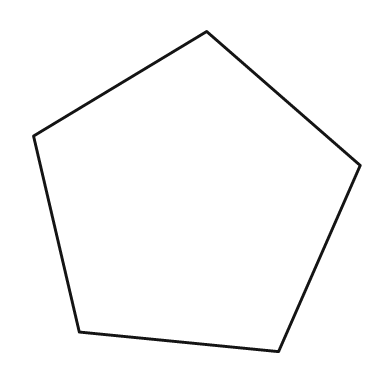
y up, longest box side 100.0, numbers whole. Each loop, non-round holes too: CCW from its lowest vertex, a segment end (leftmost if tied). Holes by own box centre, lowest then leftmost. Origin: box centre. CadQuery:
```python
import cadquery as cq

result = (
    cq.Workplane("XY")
    .moveTo(25.0, -49.0)
    .lineTo(50.0, 8.0)
    .lineTo(3.0, 49.0)
    .lineTo(-50.0, 17.0)
    .lineTo(-36.0, -43.0)
    .close()
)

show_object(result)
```